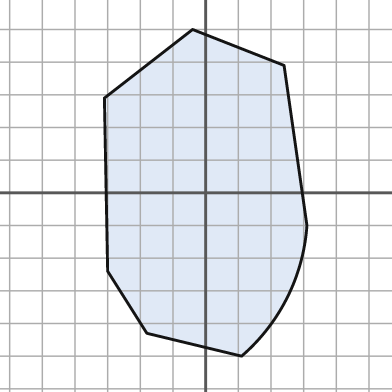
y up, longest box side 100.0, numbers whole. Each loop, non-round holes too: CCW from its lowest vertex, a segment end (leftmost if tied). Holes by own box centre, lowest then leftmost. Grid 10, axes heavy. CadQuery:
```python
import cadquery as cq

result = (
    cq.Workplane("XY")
    .moveTo(11.0, -50.0)
    .threePointArc((25.0, -32.0), (31.0, -10.0))
    .lineTo(24.0, 39.0)
    .lineTo(-4.0, 50.0)
    .lineTo(-31.0, 29.0)
    .lineTo(-30.0, -24.0)
    .lineTo(-18.0, -43.0)
    .close()
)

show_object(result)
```